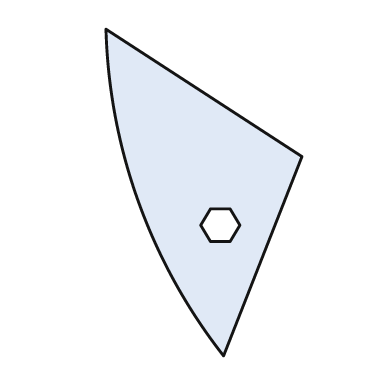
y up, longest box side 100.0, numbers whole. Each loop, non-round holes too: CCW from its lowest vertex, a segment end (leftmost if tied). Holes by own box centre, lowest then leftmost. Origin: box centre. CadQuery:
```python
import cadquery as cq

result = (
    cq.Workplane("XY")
    .moveTo(6.0, -50.0)
    .lineTo(30.0, 11.0)
    .lineTo(-30.0, 50.0)
    .threePointArc((-20.0, -3.0), (6.0, -50.0))
    .close()
    .moveTo(2.0, -15.0)
    .lineTo(8.0, -15.0)
    .lineTo(11.0, -10.0)
    .lineTo(8.0, -5.0)
    .lineTo(2.0, -5.0)
    .lineTo(-1.0, -10.0)
    .close()
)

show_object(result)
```